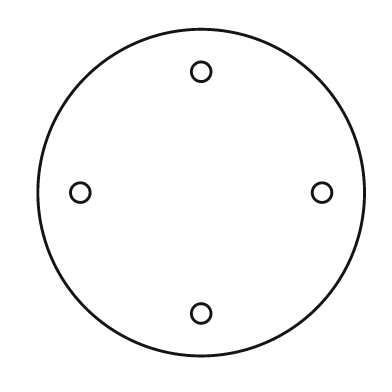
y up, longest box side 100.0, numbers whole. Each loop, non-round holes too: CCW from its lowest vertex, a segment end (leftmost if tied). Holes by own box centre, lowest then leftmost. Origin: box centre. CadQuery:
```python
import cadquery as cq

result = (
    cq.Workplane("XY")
    .moveTo(0.0, 0.0)
    .circle(50.0)
    .moveTo(0.0, -37.0)
    .circle(3.0)
    .moveTo(-37.0, 0.0)
    .circle(3.0)
    .moveTo(37.0, 0.0)
    .circle(3.0)
    .moveTo(0.0, 37.0)
    .circle(3.0)
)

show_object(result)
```